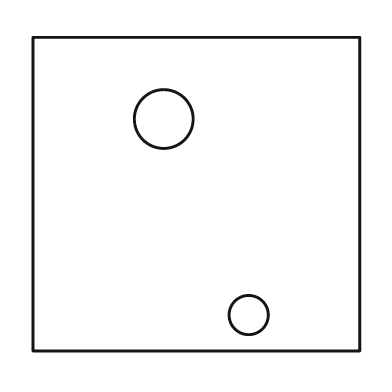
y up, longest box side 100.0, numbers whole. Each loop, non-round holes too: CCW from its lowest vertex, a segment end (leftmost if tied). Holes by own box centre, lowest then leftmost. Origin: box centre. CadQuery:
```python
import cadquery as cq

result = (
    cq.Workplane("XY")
    .moveTo(-50.0, -48.0)
    .lineTo(50.0, -48.0)
    .lineTo(50.0, 48.0)
    .lineTo(-50.0, 48.0)
    .close()
    .moveTo(16.0, -37.0)
    .circle(6.0)
    .moveTo(-10.0, 23.0)
    .circle(9.0)
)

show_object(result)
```